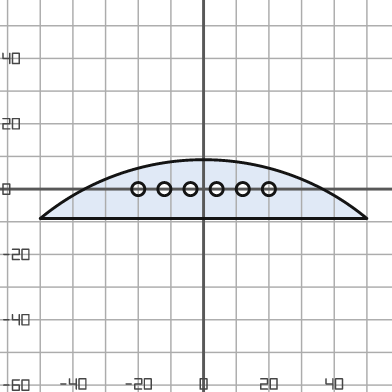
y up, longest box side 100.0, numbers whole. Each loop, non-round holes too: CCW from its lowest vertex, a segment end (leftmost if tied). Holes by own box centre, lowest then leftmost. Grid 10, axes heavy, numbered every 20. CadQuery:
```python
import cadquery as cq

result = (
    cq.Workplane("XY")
    .moveTo(-50.0, -9.0)
    .lineTo(50.0, -9.0)
    .threePointArc((0.0, 9.0), (-50.0, -9.0))
    .close()
    .moveTo(-20.0, 0.0)
    .circle(2.0)
    .moveTo(-12.0, 0.0)
    .circle(2.0)
    .moveTo(-4.0, 0.0)
    .circle(2.0)
    .moveTo(4.0, 0.0)
    .circle(2.0)
    .moveTo(12.0, 0.0)
    .circle(2.0)
    .moveTo(20.0, 0.0)
    .circle(2.0)
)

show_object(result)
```